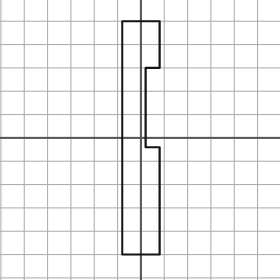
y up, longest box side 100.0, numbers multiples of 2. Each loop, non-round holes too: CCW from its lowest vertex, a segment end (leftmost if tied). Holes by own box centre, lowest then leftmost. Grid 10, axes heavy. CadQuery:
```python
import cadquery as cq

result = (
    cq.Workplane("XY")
    .moveTo(-8.0, -50.0)
    .lineTo(8.0, -50.0)
    .lineTo(8.0, -4.0)
    .lineTo(2.0, -4.0)
    .lineTo(2.0, 30.0)
    .lineTo(8.0, 30.0)
    .lineTo(8.0, 50.0)
    .lineTo(-8.0, 50.0)
    .close()
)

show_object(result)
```